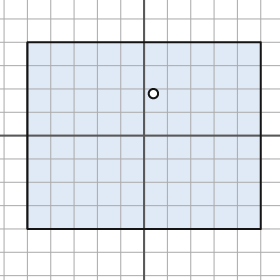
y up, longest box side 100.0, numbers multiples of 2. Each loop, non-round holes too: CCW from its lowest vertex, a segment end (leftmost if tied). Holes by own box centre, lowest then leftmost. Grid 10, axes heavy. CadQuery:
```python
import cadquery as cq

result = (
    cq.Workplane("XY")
    .moveTo(-50.0, -40.0)
    .lineTo(50.0, -40.0)
    .lineTo(50.0, 40.0)
    .lineTo(-50.0, 40.0)
    .close()
    .moveTo(4.0, 18.0)
    .circle(2.0)
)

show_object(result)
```